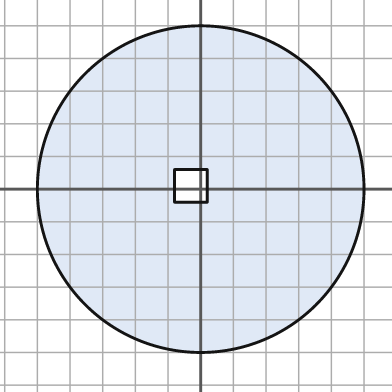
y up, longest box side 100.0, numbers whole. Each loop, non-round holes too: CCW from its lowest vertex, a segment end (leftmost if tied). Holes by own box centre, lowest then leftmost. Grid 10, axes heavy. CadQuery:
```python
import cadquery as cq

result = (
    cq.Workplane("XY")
    .moveTo(0.0, 0.0)
    .circle(50.0)
    .moveTo(-8.0, -4.0)
    .lineTo(2.0, -4.0)
    .lineTo(2.0, 6.0)
    .lineTo(-8.0, 6.0)
    .close()
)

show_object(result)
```